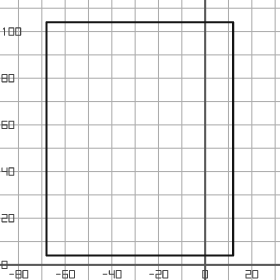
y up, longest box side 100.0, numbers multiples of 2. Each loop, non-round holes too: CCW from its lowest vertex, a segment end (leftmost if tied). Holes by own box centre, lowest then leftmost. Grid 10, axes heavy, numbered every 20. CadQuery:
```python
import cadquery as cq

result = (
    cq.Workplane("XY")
    .moveTo(-68.0, 4.0)
    .lineTo(12.0, 4.0)
    .lineTo(12.0, 104.0)
    .lineTo(-68.0, 104.0)
    .close()
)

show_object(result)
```